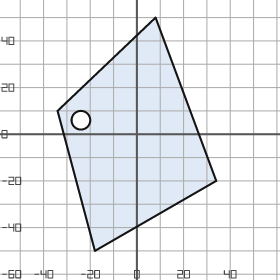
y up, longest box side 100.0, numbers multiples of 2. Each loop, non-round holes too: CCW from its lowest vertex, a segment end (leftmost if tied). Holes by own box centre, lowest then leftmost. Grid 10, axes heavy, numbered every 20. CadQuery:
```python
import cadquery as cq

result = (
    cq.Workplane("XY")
    .moveTo(-18.0, -50.0)
    .lineTo(34.0, -20.0)
    .lineTo(8.0, 50.0)
    .lineTo(-34.0, 10.0)
    .close()
    .moveTo(-24.0, 6.0)
    .circle(4.0)
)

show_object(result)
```